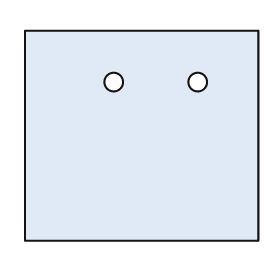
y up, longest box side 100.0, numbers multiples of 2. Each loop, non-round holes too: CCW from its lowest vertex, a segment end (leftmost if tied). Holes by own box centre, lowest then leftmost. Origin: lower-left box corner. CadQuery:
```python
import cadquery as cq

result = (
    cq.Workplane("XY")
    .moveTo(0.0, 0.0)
    .lineTo(100.0, 0.0)
    .lineTo(100.0, 90.0)
    .lineTo(0.0, 90.0)
    .close()
    .moveTo(38.0, 68.0)
    .circle(4.0)
    .moveTo(74.0, 68.0)
    .circle(4.0)
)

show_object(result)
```